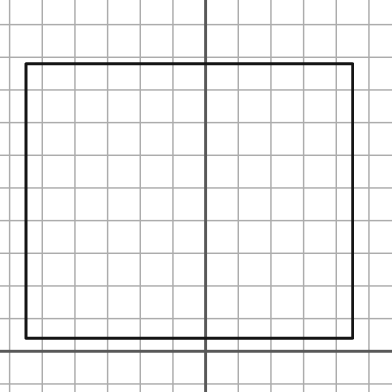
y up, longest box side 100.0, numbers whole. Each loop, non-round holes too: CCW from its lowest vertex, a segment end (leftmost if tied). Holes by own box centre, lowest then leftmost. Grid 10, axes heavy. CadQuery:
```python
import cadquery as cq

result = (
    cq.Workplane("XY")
    .moveTo(-55.0, 4.0)
    .lineTo(45.0, 4.0)
    .lineTo(45.0, 88.0)
    .lineTo(-55.0, 88.0)
    .close()
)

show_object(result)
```